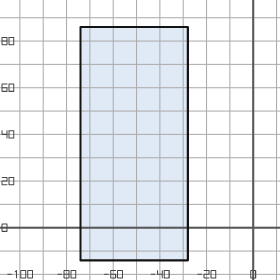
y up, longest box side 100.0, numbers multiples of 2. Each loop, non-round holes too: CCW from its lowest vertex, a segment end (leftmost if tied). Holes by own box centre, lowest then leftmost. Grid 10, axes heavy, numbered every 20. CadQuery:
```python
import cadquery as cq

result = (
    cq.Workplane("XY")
    .moveTo(-74.0, -14.0)
    .lineTo(-28.0, -14.0)
    .lineTo(-28.0, 86.0)
    .lineTo(-74.0, 86.0)
    .close()
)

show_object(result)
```